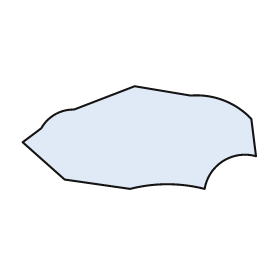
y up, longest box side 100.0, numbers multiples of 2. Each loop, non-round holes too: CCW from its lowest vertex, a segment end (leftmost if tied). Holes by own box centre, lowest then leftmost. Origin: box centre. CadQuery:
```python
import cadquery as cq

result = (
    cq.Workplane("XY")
    .moveTo(-4.0, -22.0)
    .threePointArc((12.0, -20.0), (28.0, -22.0))
    .threePointArc((36.0, -10.0), (50.0, -8.0))
    .lineTo(48.0, 8.0)
    .threePointArc((36.0, 16.0), (22.0, 18.0))
    .lineTo(-2.0, 22.0)
    .lineTo(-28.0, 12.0)
    .threePointArc((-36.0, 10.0), (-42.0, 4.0))
    .lineTo(-50.0, -2.0)
    .lineTo(-32.0, -18.0)
    .close()
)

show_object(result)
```